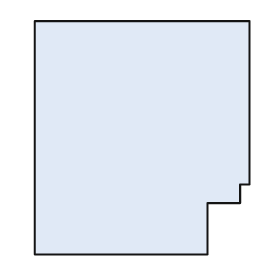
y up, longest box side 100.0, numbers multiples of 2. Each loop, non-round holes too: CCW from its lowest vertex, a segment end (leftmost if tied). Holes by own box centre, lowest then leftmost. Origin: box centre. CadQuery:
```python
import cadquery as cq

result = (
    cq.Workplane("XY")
    .moveTo(-46.0, -50.0)
    .lineTo(28.0, -50.0)
    .lineTo(28.0, -28.0)
    .lineTo(42.0, -28.0)
    .lineTo(42.0, -20.0)
    .lineTo(46.0, -20.0)
    .lineTo(46.0, 50.0)
    .lineTo(-46.0, 50.0)
    .close()
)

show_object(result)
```